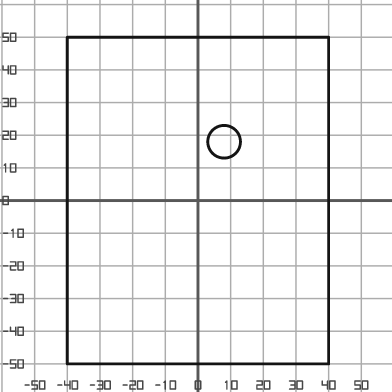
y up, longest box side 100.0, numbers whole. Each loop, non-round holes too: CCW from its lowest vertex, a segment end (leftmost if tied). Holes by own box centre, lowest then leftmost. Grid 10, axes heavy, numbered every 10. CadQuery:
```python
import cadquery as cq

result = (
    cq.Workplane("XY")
    .moveTo(-40.0, -50.0)
    .lineTo(40.0, -50.0)
    .lineTo(40.0, 50.0)
    .lineTo(-40.0, 50.0)
    .close()
    .moveTo(8.0, 18.0)
    .circle(5.0)
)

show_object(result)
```